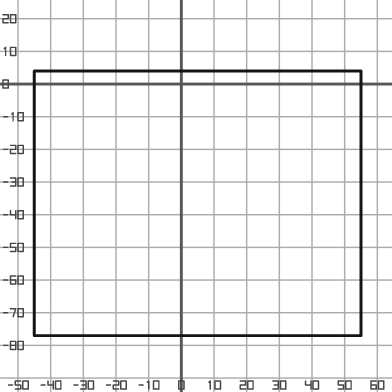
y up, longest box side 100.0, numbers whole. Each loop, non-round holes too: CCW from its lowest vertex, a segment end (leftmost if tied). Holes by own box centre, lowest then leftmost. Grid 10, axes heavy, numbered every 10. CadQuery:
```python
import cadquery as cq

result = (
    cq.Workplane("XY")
    .moveTo(-45.0, -77.0)
    .lineTo(55.0, -77.0)
    .lineTo(55.0, 4.0)
    .lineTo(-45.0, 4.0)
    .close()
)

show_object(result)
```